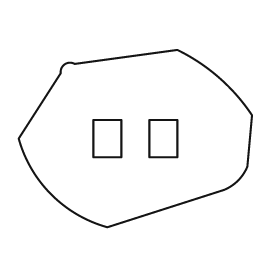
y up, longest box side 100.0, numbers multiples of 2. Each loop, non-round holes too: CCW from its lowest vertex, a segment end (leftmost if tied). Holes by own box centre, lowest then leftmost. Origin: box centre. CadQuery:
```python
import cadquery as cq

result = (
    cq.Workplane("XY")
    .moveTo(-12.0, -38.0)
    .lineTo(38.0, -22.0)
    .threePointArc((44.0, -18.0), (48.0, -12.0))
    .lineTo(50.0, 10.0)
    .threePointArc((36.0, 26.0), (18.0, 38.0))
    .lineTo(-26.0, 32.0)
    .threePointArc((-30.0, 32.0), (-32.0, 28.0))
    .lineTo(-50.0, 0.0)
    .threePointArc((-36.0, -24.0), (-12.0, -38.0))
    .close()
    .moveTo(-18.0, -8.0)
    .lineTo(-6.0, -8.0)
    .lineTo(-6.0, 8.0)
    .lineTo(-18.0, 8.0)
    .close()
    .moveTo(6.0, -8.0)
    .lineTo(18.0, -8.0)
    .lineTo(18.0, 8.0)
    .lineTo(6.0, 8.0)
    .close()
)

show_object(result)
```